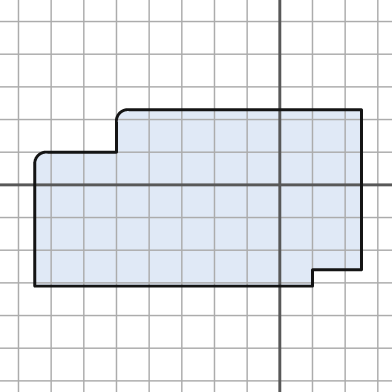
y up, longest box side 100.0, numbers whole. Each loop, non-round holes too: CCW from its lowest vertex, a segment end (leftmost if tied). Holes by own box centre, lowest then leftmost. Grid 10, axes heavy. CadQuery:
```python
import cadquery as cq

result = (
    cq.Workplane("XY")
    .moveTo(-75.0, -31.0)
    .lineTo(10.0, -31.0)
    .lineTo(10.0, -26.0)
    .lineTo(25.0, -26.0)
    .lineTo(25.0, 23.0)
    .lineTo(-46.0, 23.0)
    .threePointArc((-49.0, 22.0), (-50.0, 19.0))
    .lineTo(-50.0, 10.0)
    .lineTo(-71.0, 10.0)
    .threePointArc((-74.0, 9.0), (-75.0, 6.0))
    .close()
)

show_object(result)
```